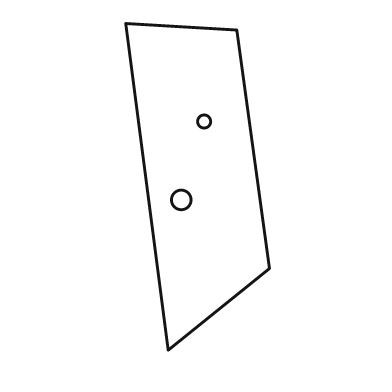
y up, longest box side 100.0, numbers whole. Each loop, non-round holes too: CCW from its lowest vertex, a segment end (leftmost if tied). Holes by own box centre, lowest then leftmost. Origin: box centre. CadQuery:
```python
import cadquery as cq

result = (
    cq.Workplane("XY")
    .moveTo(-9.0, -50.0)
    .lineTo(22.0, -25.0)
    .lineTo(12.0, 48.0)
    .lineTo(-22.0, 50.0)
    .close()
    .moveTo(-5.0, -4.0)
    .circle(3.0)
    .moveTo(2.0, 20.0)
    .circle(2.0)
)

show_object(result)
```